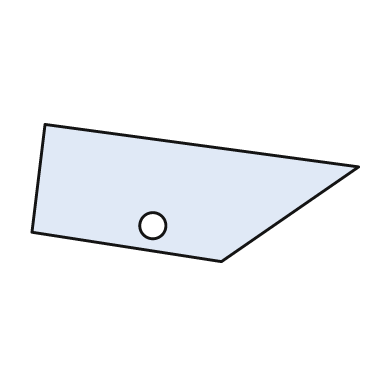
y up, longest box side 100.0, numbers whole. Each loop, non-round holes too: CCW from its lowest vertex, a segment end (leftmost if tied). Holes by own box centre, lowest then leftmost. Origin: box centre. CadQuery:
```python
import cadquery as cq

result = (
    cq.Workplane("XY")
    .moveTo(8.0, -21.0)
    .lineTo(50.0, 8.0)
    .lineTo(-46.0, 21.0)
    .lineTo(-50.0, -12.0)
    .close()
    .moveTo(-13.0, -10.0)
    .circle(4.0)
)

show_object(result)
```